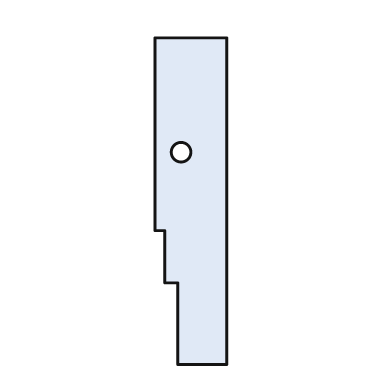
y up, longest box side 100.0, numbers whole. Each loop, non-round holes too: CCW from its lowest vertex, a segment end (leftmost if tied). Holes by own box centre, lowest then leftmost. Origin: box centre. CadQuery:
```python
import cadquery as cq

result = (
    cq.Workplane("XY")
    .moveTo(-4.0, -50.0)
    .lineTo(11.0, -50.0)
    .lineTo(11.0, 50.0)
    .lineTo(-11.0, 50.0)
    .lineTo(-11.0, -9.0)
    .lineTo(-8.0, -9.0)
    .lineTo(-8.0, -25.0)
    .lineTo(-4.0, -25.0)
    .close()
    .moveTo(-3.0, 15.0)
    .circle(3.0)
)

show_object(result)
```